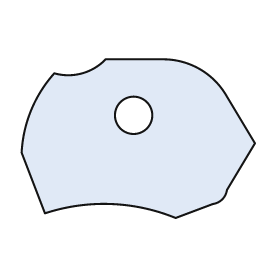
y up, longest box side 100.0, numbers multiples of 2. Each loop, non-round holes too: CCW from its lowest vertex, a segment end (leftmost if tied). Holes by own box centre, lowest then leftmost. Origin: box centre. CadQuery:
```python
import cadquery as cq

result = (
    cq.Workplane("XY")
    .moveTo(16.0, -34.0)
    .lineTo(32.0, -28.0)
    .threePointArc((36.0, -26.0), (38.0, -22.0))
    .lineTo(50.0, -2.0)
    .lineTo(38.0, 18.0)
    .threePointArc((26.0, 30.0), (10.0, 34.0))
    .lineTo(-14.0, 34.0)
    .threePointArc((-24.0, 28.0), (-36.0, 28.0))
    .threePointArc((-46.0, 12.0), (-50.0, -6.0))
    .lineTo(-40.0, -32.0)
    .threePointArc((-12.0, -28.0), (16.0, -34.0))
    .close()
    .moveTo(-2.0, 10.0)
    .circle(8.0)
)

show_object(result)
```